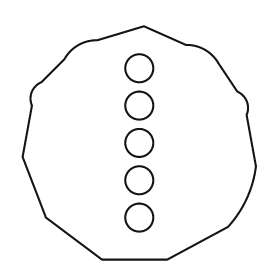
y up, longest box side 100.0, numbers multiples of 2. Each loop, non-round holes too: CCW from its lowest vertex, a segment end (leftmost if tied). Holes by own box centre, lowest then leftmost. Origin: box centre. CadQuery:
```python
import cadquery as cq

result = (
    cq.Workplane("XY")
    .moveTo(-16.0, -50.0)
    .lineTo(12.0, -50.0)
    .lineTo(38.0, -36.0)
    .threePointArc((46.0, -24.0), (50.0, -10.0))
    .lineTo(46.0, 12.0)
    .threePointArc((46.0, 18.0), (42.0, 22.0))
    .lineTo(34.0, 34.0)
    .threePointArc((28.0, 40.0), (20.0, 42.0))
    .lineTo(2.0, 50.0)
    .lineTo(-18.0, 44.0)
    .threePointArc((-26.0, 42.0), (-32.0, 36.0))
    .lineTo(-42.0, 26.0)
    .threePointArc((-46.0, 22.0), (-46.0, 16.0))
    .lineTo(-50.0, -6.0)
    .lineTo(-40.0, -32.0)
    .close()
    .moveTo(0.0, -32.0)
    .circle(6.0)
    .moveTo(0.0, -16.0)
    .circle(6.0)
    .moveTo(0.0, 0.0)
    .circle(6.0)
    .moveTo(0.0, 16.0)
    .circle(6.0)
    .moveTo(0.0, 32.0)
    .circle(6.0)
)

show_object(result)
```